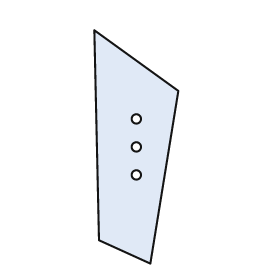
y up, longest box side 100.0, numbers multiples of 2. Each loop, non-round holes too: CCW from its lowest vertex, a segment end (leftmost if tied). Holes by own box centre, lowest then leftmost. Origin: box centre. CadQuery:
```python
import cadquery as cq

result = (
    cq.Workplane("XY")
    .moveTo(6.0, -50.0)
    .lineTo(18.0, 24.0)
    .lineTo(-18.0, 50.0)
    .lineTo(-16.0, -40.0)
    .close()
    .moveTo(0.0, -12.0)
    .circle(2.0)
    .moveTo(0.0, 0.0)
    .circle(2.0)
    .moveTo(0.0, 12.0)
    .circle(2.0)
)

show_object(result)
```